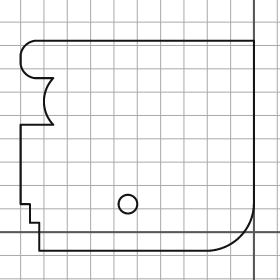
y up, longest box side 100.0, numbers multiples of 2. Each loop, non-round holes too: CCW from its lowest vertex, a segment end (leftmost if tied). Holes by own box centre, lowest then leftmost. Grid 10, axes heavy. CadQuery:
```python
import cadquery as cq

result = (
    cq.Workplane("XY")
    .moveTo(-92.0, -8.0)
    .lineTo(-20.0, -8.0)
    .threePointArc((-6.0, -2.0), (0.0, 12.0))
    .lineTo(0.0, 82.0)
    .lineTo(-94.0, 82.0)
    .threePointArc((-98.0, 80.0), (-100.0, 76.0))
    .lineTo(-100.0, 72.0)
    .threePointArc((-98.0, 68.0), (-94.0, 66.0))
    .lineTo(-86.0, 66.0)
    .threePointArc((-90.0, 56.0), (-86.0, 46.0))
    .lineTo(-100.0, 46.0)
    .lineTo(-100.0, 12.0)
    .lineTo(-96.0, 12.0)
    .lineTo(-96.0, 4.0)
    .lineTo(-92.0, 4.0)
    .close()
    .moveTo(-54.0, 12.0)
    .circle(4.0)
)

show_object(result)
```